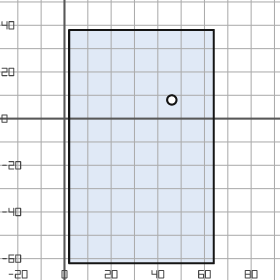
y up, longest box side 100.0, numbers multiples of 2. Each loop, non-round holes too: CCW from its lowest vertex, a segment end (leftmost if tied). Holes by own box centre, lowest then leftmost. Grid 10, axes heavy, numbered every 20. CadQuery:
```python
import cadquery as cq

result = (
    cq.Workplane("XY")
    .moveTo(2.0, -62.0)
    .lineTo(64.0, -62.0)
    .lineTo(64.0, 38.0)
    .lineTo(2.0, 38.0)
    .close()
    .moveTo(46.0, 8.0)
    .circle(2.0)
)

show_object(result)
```